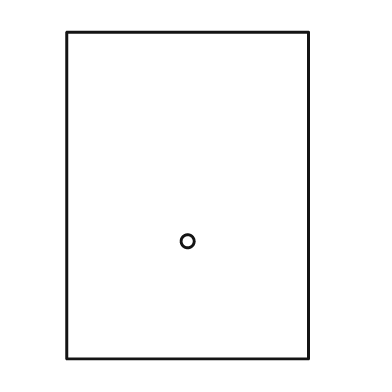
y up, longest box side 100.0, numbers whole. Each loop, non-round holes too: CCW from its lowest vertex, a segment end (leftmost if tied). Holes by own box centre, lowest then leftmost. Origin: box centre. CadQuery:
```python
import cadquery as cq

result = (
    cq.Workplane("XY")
    .moveTo(-37.0, -50.0)
    .lineTo(37.0, -50.0)
    .lineTo(37.0, 50.0)
    .lineTo(-37.0, 50.0)
    .close()
    .moveTo(0.0, -14.0)
    .circle(2.0)
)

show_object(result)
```